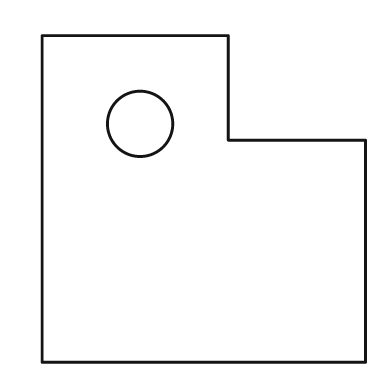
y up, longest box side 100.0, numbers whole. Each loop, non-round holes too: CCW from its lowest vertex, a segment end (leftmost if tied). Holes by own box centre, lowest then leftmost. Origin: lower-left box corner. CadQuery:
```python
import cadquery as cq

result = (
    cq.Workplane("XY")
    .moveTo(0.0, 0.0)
    .lineTo(99.0, 0.0)
    .lineTo(99.0, 68.0)
    .lineTo(57.0, 68.0)
    .lineTo(57.0, 100.0)
    .lineTo(0.0, 100.0)
    .close()
    .moveTo(30.0, 73.0)
    .circle(10.0)
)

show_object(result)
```